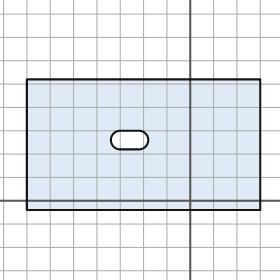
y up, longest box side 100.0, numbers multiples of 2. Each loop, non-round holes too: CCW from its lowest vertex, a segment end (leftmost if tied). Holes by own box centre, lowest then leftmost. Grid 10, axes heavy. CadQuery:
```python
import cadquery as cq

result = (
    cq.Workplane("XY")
    .moveTo(-70.0, -4.0)
    .lineTo(30.0, -4.0)
    .lineTo(30.0, 52.0)
    .lineTo(-70.0, 52.0)
    .close()
    .moveTo(-30.0, 22.0)
    .lineTo(-22.0, 22.0)
    .threePointArc((-18.0, 26.0), (-22.0, 30.0))
    .lineTo(-30.0, 30.0)
    .threePointArc((-34.0, 26.0), (-30.0, 22.0))
    .close()
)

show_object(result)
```